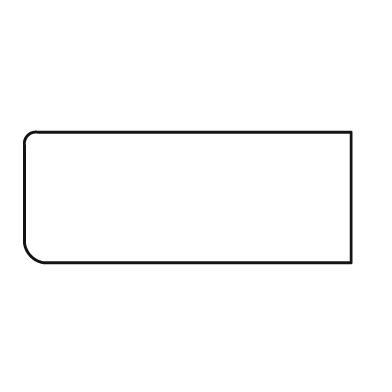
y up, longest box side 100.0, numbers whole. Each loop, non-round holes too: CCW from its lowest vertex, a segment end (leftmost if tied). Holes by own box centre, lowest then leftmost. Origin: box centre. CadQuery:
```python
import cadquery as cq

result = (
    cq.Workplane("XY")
    .moveTo(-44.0, -20.0)
    .lineTo(50.0, -20.0)
    .lineTo(50.0, 20.0)
    .lineTo(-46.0, 20.0)
    .threePointArc((-49.0, 19.0), (-50.0, 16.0))
    .lineTo(-50.0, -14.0)
    .threePointArc((-48.0, -18.0), (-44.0, -20.0))
    .close()
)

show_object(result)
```